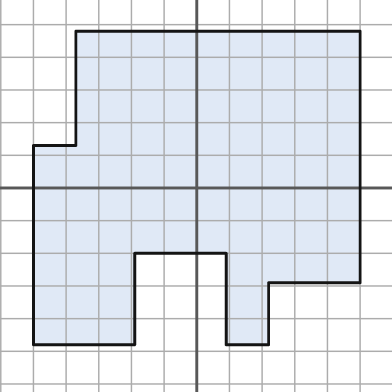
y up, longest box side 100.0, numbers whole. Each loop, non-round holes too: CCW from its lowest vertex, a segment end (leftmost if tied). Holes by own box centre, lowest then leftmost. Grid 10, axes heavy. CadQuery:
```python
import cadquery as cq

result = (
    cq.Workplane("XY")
    .moveTo(-50.0, -48.0)
    .lineTo(-19.0, -48.0)
    .lineTo(-19.0, -20.0)
    .lineTo(9.0, -20.0)
    .lineTo(9.0, -48.0)
    .lineTo(22.0, -48.0)
    .lineTo(22.0, -29.0)
    .lineTo(50.0, -29.0)
    .lineTo(50.0, 48.0)
    .lineTo(-37.0, 48.0)
    .lineTo(-37.0, 13.0)
    .lineTo(-50.0, 13.0)
    .close()
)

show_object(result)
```